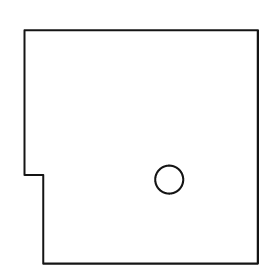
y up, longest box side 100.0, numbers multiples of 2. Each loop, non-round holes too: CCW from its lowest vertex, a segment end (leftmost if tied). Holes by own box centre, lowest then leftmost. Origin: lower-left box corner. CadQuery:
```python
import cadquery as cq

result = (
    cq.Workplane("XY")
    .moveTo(8.0, 0.0)
    .lineTo(100.0, 0.0)
    .lineTo(100.0, 100.0)
    .lineTo(0.0, 100.0)
    .lineTo(0.0, 38.0)
    .lineTo(8.0, 38.0)
    .close()
    .moveTo(62.0, 36.0)
    .circle(6.0)
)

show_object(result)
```